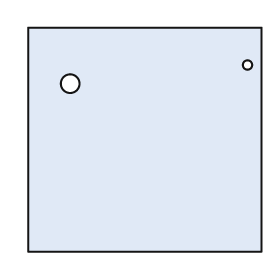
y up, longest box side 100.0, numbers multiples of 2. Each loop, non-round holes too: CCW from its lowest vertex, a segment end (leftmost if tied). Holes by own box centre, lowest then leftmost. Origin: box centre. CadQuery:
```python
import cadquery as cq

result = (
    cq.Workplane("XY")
    .moveTo(-50.0, -48.0)
    .lineTo(50.0, -48.0)
    .lineTo(50.0, 48.0)
    .lineTo(-50.0, 48.0)
    .close()
    .moveTo(-32.0, 24.0)
    .circle(4.0)
    .moveTo(44.0, 32.0)
    .circle(2.0)
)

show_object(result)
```